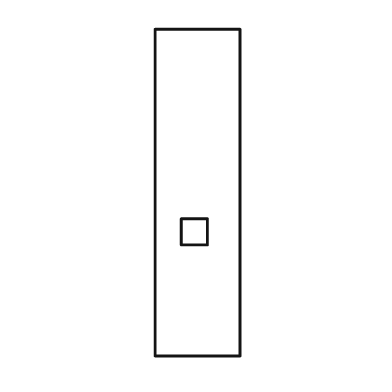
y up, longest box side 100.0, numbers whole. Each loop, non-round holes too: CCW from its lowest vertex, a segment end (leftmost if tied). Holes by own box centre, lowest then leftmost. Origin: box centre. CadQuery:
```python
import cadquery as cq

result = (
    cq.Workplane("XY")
    .moveTo(-13.0, -50.0)
    .lineTo(13.0, -50.0)
    .lineTo(13.0, 50.0)
    .lineTo(-13.0, 50.0)
    .close()
    .moveTo(-5.0, -16.0)
    .lineTo(3.0, -16.0)
    .lineTo(3.0, -8.0)
    .lineTo(-5.0, -8.0)
    .close()
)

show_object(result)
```